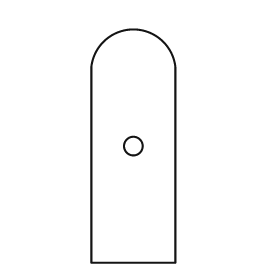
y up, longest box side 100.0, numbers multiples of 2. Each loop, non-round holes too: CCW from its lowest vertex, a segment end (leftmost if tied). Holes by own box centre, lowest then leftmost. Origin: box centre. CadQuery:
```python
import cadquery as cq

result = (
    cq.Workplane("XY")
    .moveTo(-18.0, -50.0)
    .lineTo(18.0, -50.0)
    .lineTo(18.0, 34.0)
    .threePointArc((0.0, 50.0), (-18.0, 34.0))
    .close()
    .moveTo(0.0, 0.0)
    .circle(4.0)
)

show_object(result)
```